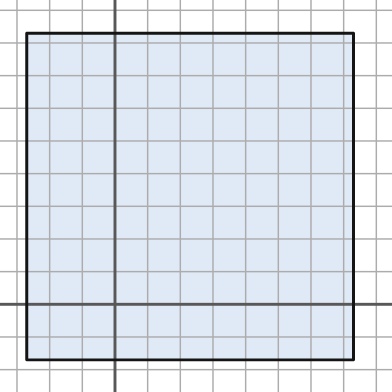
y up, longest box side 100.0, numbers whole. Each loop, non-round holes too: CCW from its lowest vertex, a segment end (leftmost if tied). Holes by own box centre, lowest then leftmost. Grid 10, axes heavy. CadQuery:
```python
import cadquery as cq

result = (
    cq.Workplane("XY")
    .moveTo(-27.0, -17.0)
    .lineTo(73.0, -17.0)
    .lineTo(73.0, 83.0)
    .lineTo(-27.0, 83.0)
    .close()
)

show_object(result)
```